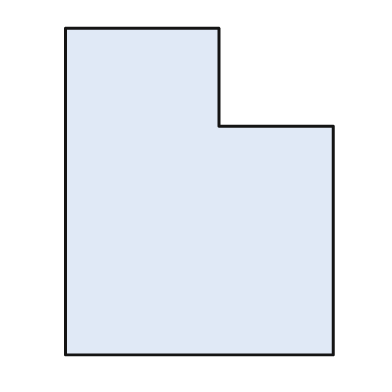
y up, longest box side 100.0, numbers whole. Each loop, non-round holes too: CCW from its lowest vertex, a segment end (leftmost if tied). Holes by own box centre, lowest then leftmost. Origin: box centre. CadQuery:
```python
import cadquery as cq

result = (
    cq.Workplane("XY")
    .moveTo(-41.0, -50.0)
    .lineTo(41.0, -50.0)
    .lineTo(41.0, 20.0)
    .lineTo(6.0, 20.0)
    .lineTo(6.0, 50.0)
    .lineTo(-41.0, 50.0)
    .close()
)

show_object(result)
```